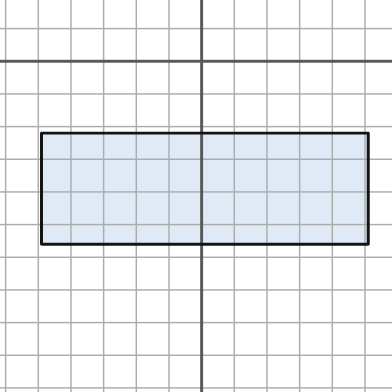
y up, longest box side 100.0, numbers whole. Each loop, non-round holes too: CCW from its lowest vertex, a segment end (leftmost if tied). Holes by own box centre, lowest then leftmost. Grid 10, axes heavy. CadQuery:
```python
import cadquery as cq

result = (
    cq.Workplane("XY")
    .moveTo(-49.0, -56.0)
    .lineTo(51.0, -56.0)
    .lineTo(51.0, -22.0)
    .lineTo(-49.0, -22.0)
    .close()
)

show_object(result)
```